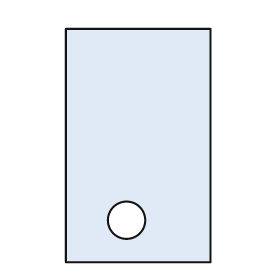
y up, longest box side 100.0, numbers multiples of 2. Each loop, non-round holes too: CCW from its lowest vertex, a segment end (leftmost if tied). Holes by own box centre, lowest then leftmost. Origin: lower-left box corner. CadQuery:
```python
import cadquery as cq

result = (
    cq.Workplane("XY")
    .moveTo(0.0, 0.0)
    .lineTo(62.0, 0.0)
    .lineTo(62.0, 100.0)
    .lineTo(0.0, 100.0)
    .close()
    .moveTo(26.0, 18.0)
    .circle(8.0)
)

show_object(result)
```